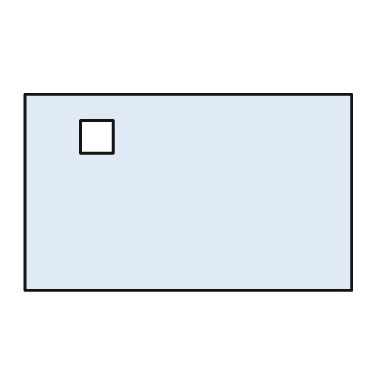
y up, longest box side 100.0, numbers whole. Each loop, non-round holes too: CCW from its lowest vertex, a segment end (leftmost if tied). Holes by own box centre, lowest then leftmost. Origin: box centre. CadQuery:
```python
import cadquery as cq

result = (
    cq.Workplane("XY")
    .moveTo(-50.0, -30.0)
    .lineTo(50.0, -30.0)
    .lineTo(50.0, 30.0)
    .lineTo(-50.0, 30.0)
    .close()
    .moveTo(-33.0, 12.0)
    .lineTo(-23.0, 12.0)
    .lineTo(-23.0, 22.0)
    .lineTo(-33.0, 22.0)
    .close()
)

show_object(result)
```